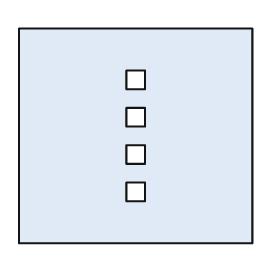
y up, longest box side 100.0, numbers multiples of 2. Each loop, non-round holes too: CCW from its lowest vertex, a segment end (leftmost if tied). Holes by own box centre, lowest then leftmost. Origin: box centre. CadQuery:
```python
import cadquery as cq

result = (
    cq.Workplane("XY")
    .moveTo(-50.0, -46.0)
    .lineTo(50.0, -46.0)
    .lineTo(50.0, 46.0)
    .lineTo(-50.0, 46.0)
    .close()
    .moveTo(-4.0, -28.0)
    .lineTo(4.0, -28.0)
    .lineTo(4.0, -20.0)
    .lineTo(-4.0, -20.0)
    .close()
    .moveTo(-4.0, -12.0)
    .lineTo(4.0, -12.0)
    .lineTo(4.0, -4.0)
    .lineTo(-4.0, -4.0)
    .close()
    .moveTo(-4.0, 4.0)
    .lineTo(4.0, 4.0)
    .lineTo(4.0, 12.0)
    .lineTo(-4.0, 12.0)
    .close()
    .moveTo(-4.0, 20.0)
    .lineTo(4.0, 20.0)
    .lineTo(4.0, 28.0)
    .lineTo(-4.0, 28.0)
    .close()
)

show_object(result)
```